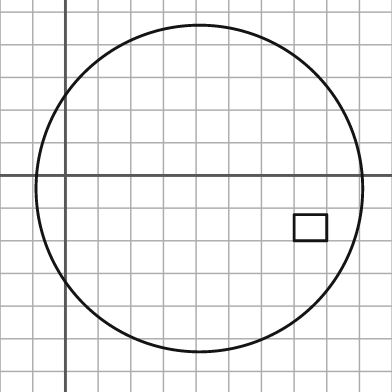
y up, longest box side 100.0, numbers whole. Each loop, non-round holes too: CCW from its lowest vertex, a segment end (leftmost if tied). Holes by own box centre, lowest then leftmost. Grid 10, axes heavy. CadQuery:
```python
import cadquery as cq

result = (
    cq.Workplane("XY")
    .moveTo(41.0, -4.0)
    .circle(50.0)
    .moveTo(70.0, -20.0)
    .lineTo(80.0, -20.0)
    .lineTo(80.0, -12.0)
    .lineTo(70.0, -12.0)
    .close()
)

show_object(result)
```